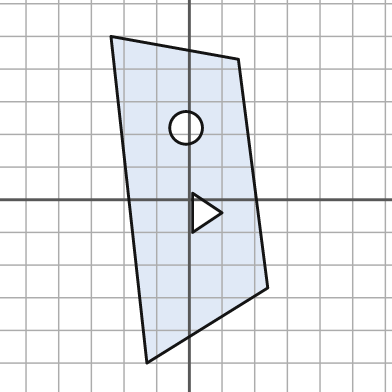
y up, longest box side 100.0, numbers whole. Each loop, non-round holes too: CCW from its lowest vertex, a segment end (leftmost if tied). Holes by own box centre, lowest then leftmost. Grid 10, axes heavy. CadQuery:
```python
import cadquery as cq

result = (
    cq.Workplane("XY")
    .moveTo(-13.0, -50.0)
    .lineTo(24.0, -27.0)
    .lineTo(15.0, 43.0)
    .lineTo(-24.0, 50.0)
    .close()
    .moveTo(1.0, -10.0)
    .lineTo(10.0, -4.0)
    .lineTo(1.0, 2.0)
    .close()
    .moveTo(-1.0, 22.0)
    .circle(5.0)
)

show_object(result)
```